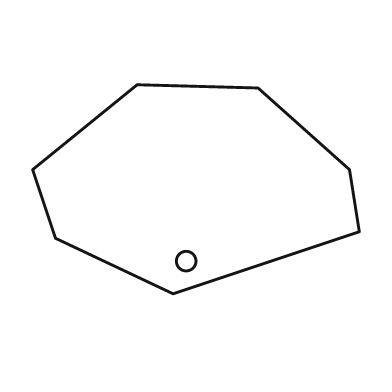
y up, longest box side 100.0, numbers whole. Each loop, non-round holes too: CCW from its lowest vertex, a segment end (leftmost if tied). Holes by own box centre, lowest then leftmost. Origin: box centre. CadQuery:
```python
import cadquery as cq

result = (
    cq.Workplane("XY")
    .moveTo(-7.0, -32.0)
    .lineTo(50.0, -13.0)
    .lineTo(47.0, 6.0)
    .lineTo(19.0, 31.0)
    .lineTo(-18.0, 32.0)
    .lineTo(-50.0, 6.0)
    .lineTo(-43.0, -15.0)
    .close()
    .moveTo(-3.0, -22.0)
    .circle(3.0)
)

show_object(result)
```